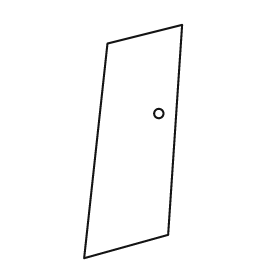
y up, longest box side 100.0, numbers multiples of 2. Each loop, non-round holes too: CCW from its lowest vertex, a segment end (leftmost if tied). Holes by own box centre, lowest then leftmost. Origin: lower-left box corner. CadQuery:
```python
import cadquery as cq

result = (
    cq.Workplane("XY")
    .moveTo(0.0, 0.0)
    .lineTo(36.0, 10.0)
    .lineTo(42.0, 100.0)
    .lineTo(10.0, 92.0)
    .close()
    .moveTo(32.0, 62.0)
    .circle(2.0)
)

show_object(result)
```